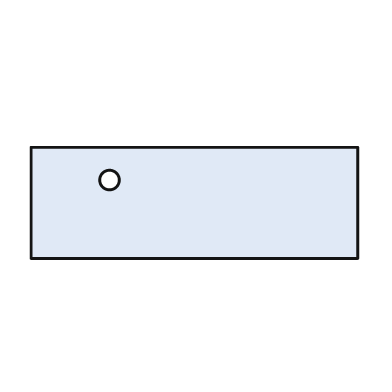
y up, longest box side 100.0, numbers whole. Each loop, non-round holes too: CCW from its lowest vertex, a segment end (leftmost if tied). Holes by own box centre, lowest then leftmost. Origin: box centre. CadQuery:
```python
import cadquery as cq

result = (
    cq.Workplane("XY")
    .moveTo(-50.0, -17.0)
    .lineTo(50.0, -17.0)
    .lineTo(50.0, 17.0)
    .lineTo(-50.0, 17.0)
    .close()
    .moveTo(-26.0, 7.0)
    .circle(3.0)
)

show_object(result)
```